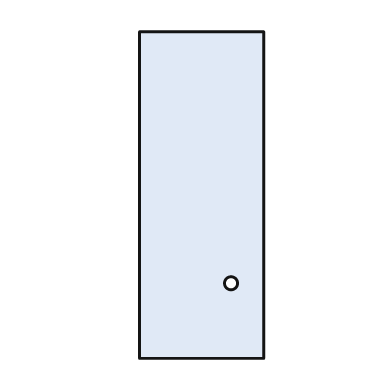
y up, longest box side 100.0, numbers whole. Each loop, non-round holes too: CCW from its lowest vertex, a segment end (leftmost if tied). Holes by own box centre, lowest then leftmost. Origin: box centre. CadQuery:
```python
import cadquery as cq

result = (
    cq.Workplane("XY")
    .moveTo(-19.0, -50.0)
    .lineTo(19.0, -50.0)
    .lineTo(19.0, 50.0)
    .lineTo(-19.0, 50.0)
    .close()
    .moveTo(9.0, -27.0)
    .circle(2.0)
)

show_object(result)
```